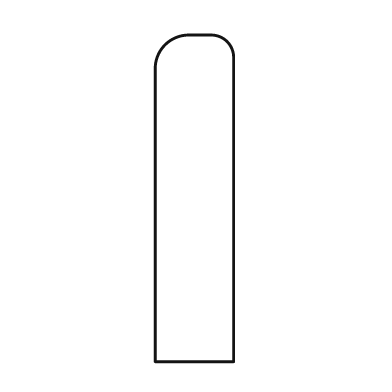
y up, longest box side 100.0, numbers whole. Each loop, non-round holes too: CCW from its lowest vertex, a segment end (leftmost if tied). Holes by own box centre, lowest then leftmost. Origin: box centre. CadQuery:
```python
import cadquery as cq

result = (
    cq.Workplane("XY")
    .moveTo(-12.0, -50.0)
    .lineTo(12.0, -50.0)
    .lineTo(12.0, 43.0)
    .threePointArc((10.0, 48.0), (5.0, 50.0))
    .lineTo(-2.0, 50.0)
    .threePointArc((-9.0, 47.0), (-12.0, 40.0))
    .close()
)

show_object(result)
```